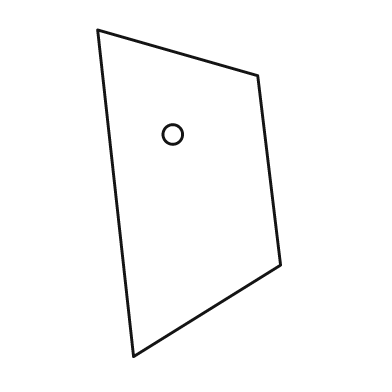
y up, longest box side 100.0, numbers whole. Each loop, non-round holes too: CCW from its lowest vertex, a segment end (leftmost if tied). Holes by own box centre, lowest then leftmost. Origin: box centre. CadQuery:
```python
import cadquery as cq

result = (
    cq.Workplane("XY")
    .moveTo(-17.0, -50.0)
    .lineTo(28.0, -22.0)
    .lineTo(21.0, 36.0)
    .lineTo(-28.0, 50.0)
    .close()
    .moveTo(-5.0, 18.0)
    .circle(3.0)
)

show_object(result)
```